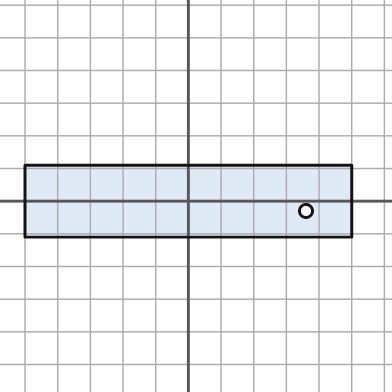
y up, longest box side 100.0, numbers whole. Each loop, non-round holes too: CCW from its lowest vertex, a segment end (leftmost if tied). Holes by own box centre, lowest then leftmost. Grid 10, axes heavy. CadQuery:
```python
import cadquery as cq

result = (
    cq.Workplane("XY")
    .moveTo(-50.0, -11.0)
    .lineTo(50.0, -11.0)
    .lineTo(50.0, 11.0)
    .lineTo(-50.0, 11.0)
    .close()
    .moveTo(36.0, -3.0)
    .circle(2.0)
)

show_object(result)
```